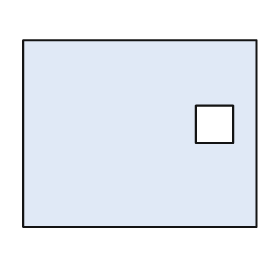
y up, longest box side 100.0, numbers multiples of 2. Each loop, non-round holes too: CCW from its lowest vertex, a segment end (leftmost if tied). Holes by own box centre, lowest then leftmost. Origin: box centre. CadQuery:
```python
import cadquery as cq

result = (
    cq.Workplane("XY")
    .moveTo(-50.0, -40.0)
    .lineTo(50.0, -40.0)
    .lineTo(50.0, 40.0)
    .lineTo(-50.0, 40.0)
    .close()
    .moveTo(24.0, -4.0)
    .lineTo(40.0, -4.0)
    .lineTo(40.0, 12.0)
    .lineTo(24.0, 12.0)
    .close()
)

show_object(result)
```